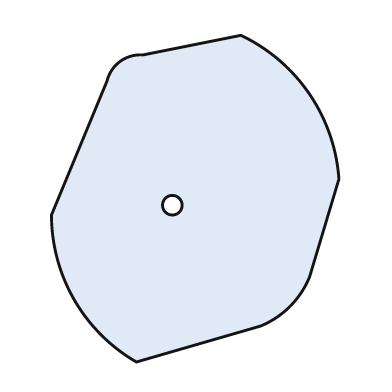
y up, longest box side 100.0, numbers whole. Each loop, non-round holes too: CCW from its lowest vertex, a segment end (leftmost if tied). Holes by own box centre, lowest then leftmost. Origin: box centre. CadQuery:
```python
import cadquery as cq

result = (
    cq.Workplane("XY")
    .moveTo(-18.0, -50.0)
    .lineTo(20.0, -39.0)
    .threePointArc((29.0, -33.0), (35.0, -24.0))
    .lineTo(44.0, 6.0)
    .threePointArc((35.0, 32.0), (14.0, 50.0))
    .lineTo(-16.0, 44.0)
    .threePointArc((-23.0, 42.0), (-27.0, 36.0))
    .lineTo(-44.0, -5.0)
    .threePointArc((-37.0, -31.0), (-18.0, -50.0))
    .close()
    .moveTo(-7.0, -2.0)
    .circle(3.0)
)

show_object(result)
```